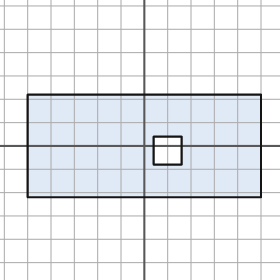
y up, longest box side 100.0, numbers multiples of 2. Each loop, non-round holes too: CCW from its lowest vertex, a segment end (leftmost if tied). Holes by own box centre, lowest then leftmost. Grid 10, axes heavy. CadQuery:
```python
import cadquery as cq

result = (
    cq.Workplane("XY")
    .moveTo(-50.0, -22.0)
    .lineTo(50.0, -22.0)
    .lineTo(50.0, 22.0)
    .lineTo(-50.0, 22.0)
    .close()
    .moveTo(4.0, -8.0)
    .lineTo(16.0, -8.0)
    .lineTo(16.0, 4.0)
    .lineTo(4.0, 4.0)
    .close()
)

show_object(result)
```